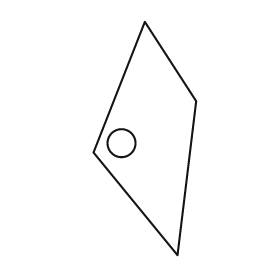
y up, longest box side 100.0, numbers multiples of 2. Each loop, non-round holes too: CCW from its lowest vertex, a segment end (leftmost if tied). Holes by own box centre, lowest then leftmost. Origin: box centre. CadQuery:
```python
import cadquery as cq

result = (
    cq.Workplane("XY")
    .moveTo(14.0, -50.0)
    .lineTo(22.0, 16.0)
    .lineTo(0.0, 50.0)
    .lineTo(-22.0, -6.0)
    .close()
    .moveTo(-10.0, -2.0)
    .circle(6.0)
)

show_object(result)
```